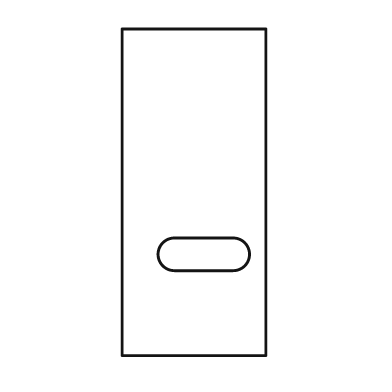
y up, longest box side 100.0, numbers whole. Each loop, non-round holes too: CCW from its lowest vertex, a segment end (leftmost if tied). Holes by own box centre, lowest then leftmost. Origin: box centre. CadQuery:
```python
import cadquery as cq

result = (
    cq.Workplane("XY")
    .moveTo(-22.0, -50.0)
    .lineTo(22.0, -50.0)
    .lineTo(22.0, 50.0)
    .lineTo(-22.0, 50.0)
    .close()
    .moveTo(-6.0, -24.0)
    .lineTo(12.0, -24.0)
    .threePointArc((17.0, -19.0), (12.0, -14.0))
    .lineTo(-6.0, -14.0)
    .threePointArc((-11.0, -19.0), (-6.0, -24.0))
    .close()
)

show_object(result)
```